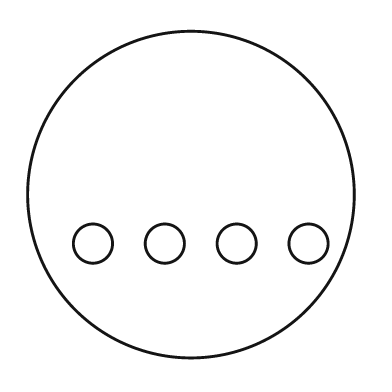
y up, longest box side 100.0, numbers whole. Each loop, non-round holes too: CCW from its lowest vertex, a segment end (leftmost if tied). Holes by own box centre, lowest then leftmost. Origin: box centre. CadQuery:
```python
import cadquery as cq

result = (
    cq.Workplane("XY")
    .moveTo(0.0, 0.0)
    .circle(50.0)
    .moveTo(-30.0, -15.0)
    .circle(6.0)
    .moveTo(-8.0, -15.0)
    .circle(6.0)
    .moveTo(14.0, -15.0)
    .circle(6.0)
    .moveTo(36.0, -15.0)
    .circle(6.0)
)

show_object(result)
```